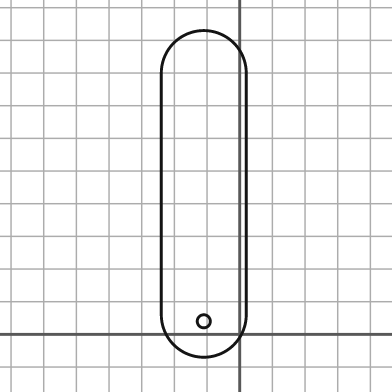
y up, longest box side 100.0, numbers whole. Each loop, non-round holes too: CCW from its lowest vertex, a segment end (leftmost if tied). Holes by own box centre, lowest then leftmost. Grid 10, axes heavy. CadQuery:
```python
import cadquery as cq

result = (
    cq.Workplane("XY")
    .moveTo(-24.0, 6.0)
    .threePointArc((-11.0, -7.0), (2.0, 6.0))
    .lineTo(2.0, 80.0)
    .threePointArc((-11.0, 93.0), (-24.0, 80.0))
    .close()
    .moveTo(-11.0, 4.0)
    .circle(2.0)
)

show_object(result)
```